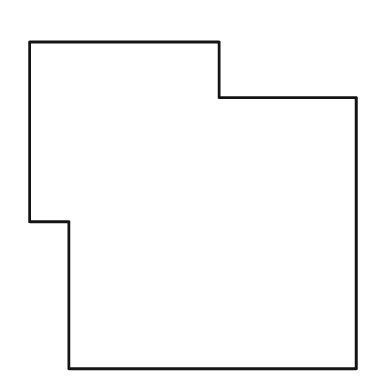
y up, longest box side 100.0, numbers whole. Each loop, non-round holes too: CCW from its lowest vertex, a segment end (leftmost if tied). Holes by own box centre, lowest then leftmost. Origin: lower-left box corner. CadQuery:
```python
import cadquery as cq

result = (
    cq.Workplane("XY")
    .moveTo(12.0, 0.0)
    .lineTo(100.0, 0.0)
    .lineTo(100.0, 83.0)
    .lineTo(58.0, 83.0)
    .lineTo(58.0, 100.0)
    .lineTo(0.0, 100.0)
    .lineTo(0.0, 45.0)
    .lineTo(12.0, 45.0)
    .close()
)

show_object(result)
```